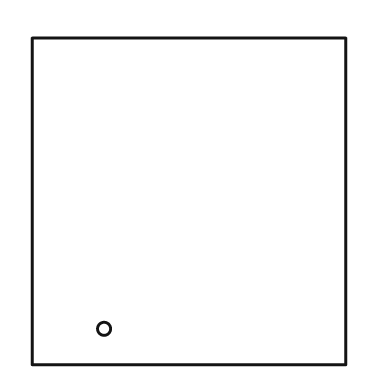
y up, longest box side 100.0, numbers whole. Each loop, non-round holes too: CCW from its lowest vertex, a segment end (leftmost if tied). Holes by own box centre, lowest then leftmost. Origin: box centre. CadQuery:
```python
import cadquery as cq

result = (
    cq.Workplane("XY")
    .moveTo(-48.0, -50.0)
    .lineTo(48.0, -50.0)
    .lineTo(48.0, 50.0)
    .lineTo(-48.0, 50.0)
    .close()
    .moveTo(-26.0, -39.0)
    .circle(2.0)
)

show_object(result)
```